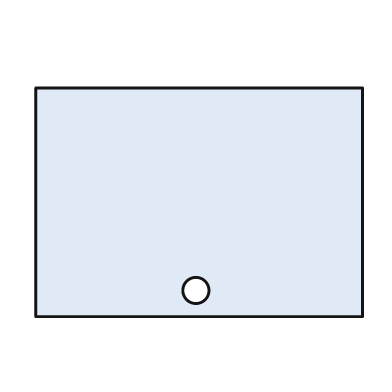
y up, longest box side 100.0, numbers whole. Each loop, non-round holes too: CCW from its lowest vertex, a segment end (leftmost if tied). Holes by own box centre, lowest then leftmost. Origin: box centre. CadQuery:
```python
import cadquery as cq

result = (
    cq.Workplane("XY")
    .moveTo(-50.0, -35.0)
    .lineTo(50.0, -35.0)
    .lineTo(50.0, 35.0)
    .lineTo(-50.0, 35.0)
    .close()
    .moveTo(-1.0, -27.0)
    .circle(4.0)
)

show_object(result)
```